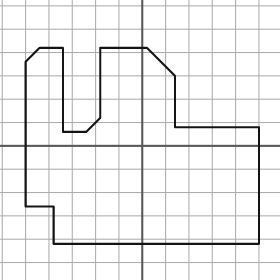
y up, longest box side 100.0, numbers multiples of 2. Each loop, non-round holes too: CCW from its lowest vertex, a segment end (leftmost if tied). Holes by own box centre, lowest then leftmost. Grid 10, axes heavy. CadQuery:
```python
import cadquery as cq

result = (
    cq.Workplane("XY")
    .moveTo(-38.0, -42.0)
    .lineTo(50.0, -42.0)
    .lineTo(50.0, 8.0)
    .lineTo(14.0, 8.0)
    .lineTo(14.0, 30.0)
    .lineTo(2.0, 42.0)
    .lineTo(-18.0, 42.0)
    .lineTo(-18.0, 12.0)
    .lineTo(-24.0, 6.0)
    .lineTo(-34.0, 6.0)
    .lineTo(-34.0, 42.0)
    .lineTo(-44.0, 42.0)
    .lineTo(-50.0, 36.0)
    .lineTo(-50.0, -26.0)
    .lineTo(-38.0, -26.0)
    .close()
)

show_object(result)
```